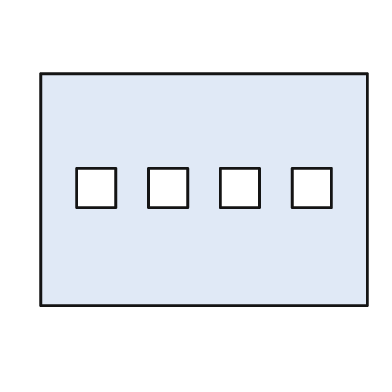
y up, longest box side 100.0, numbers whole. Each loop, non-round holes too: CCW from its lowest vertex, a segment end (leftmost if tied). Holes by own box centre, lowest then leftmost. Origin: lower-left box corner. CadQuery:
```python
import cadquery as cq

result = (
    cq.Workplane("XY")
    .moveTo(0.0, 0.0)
    .lineTo(100.0, 0.0)
    .lineTo(100.0, 71.0)
    .lineTo(0.0, 71.0)
    .close()
    .moveTo(11.0, 30.0)
    .lineTo(23.0, 30.0)
    .lineTo(23.0, 42.0)
    .lineTo(11.0, 42.0)
    .close()
    .moveTo(33.0, 30.0)
    .lineTo(45.0, 30.0)
    .lineTo(45.0, 42.0)
    .lineTo(33.0, 42.0)
    .close()
    .moveTo(55.0, 30.0)
    .lineTo(67.0, 30.0)
    .lineTo(67.0, 42.0)
    .lineTo(55.0, 42.0)
    .close()
    .moveTo(77.0, 30.0)
    .lineTo(89.0, 30.0)
    .lineTo(89.0, 42.0)
    .lineTo(77.0, 42.0)
    .close()
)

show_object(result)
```